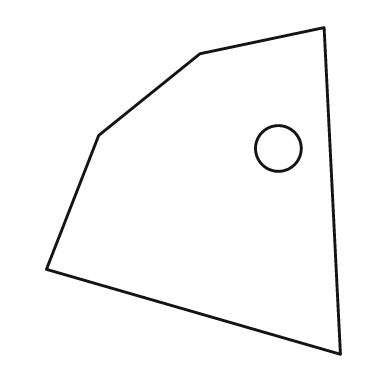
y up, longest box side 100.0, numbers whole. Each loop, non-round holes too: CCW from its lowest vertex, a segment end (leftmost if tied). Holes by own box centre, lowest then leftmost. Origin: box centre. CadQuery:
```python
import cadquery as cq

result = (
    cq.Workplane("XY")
    .moveTo(45.0, -50.0)
    .lineTo(40.0, 50.0)
    .lineTo(2.0, 42.0)
    .lineTo(-29.0, 17.0)
    .lineTo(-45.0, -24.0)
    .close()
    .moveTo(26.0, 13.0)
    .circle(7.0)
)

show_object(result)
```